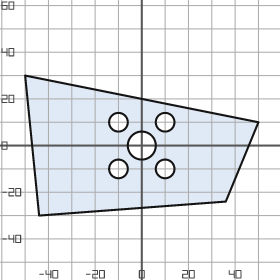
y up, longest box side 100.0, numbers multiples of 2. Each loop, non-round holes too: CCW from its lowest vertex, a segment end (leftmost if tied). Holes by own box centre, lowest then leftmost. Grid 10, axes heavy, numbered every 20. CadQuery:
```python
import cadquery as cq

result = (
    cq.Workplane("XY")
    .moveTo(-44.0, -30.0)
    .lineTo(36.0, -24.0)
    .lineTo(50.0, 10.0)
    .lineTo(-50.0, 30.0)
    .close()
    .moveTo(-10.0, -10.0)
    .circle(4.0)
    .moveTo(10.0, -10.0)
    .circle(4.0)
    .moveTo(0.0, 0.0)
    .circle(6.0)
    .moveTo(-10.0, 10.0)
    .circle(4.0)
    .moveTo(10.0, 10.0)
    .circle(4.0)
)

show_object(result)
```